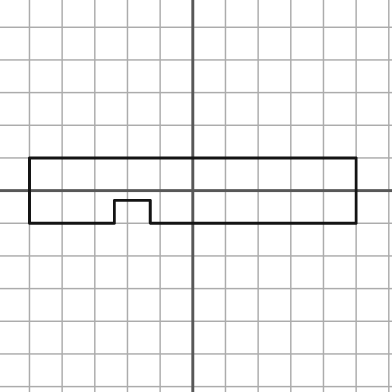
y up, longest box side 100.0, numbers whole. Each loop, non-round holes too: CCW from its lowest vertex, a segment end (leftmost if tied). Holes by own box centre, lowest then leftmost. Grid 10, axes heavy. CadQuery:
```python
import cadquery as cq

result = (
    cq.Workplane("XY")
    .moveTo(-50.0, -10.0)
    .lineTo(-24.0, -10.0)
    .lineTo(-24.0, -3.0)
    .lineTo(-13.0, -3.0)
    .lineTo(-13.0, -10.0)
    .lineTo(50.0, -10.0)
    .lineTo(50.0, 10.0)
    .lineTo(-50.0, 10.0)
    .close()
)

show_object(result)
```